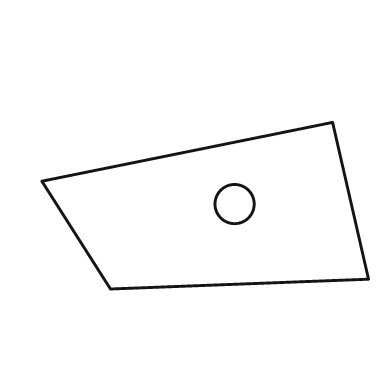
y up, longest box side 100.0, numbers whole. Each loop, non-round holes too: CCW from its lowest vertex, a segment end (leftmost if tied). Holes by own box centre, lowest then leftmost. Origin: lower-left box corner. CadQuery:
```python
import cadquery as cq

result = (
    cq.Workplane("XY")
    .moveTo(21.0, 0.0)
    .lineTo(100.0, 3.0)
    .lineTo(89.0, 51.0)
    .lineTo(0.0, 33.0)
    .close()
    .moveTo(59.0, 26.0)
    .circle(6.0)
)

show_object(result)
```